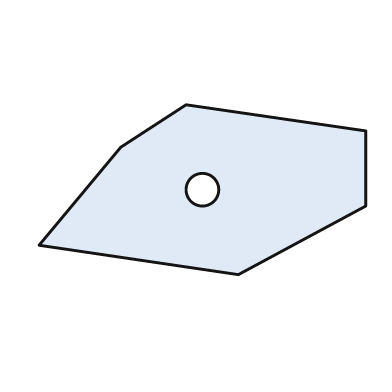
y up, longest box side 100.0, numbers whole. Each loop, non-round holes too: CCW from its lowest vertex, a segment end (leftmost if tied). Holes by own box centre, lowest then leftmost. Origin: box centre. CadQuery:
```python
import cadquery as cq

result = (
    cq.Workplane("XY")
    .moveTo(11.0, -26.0)
    .lineTo(50.0, -5.0)
    .lineTo(50.0, 18.0)
    .lineTo(-5.0, 26.0)
    .lineTo(-25.0, 13.0)
    .lineTo(-50.0, -17.0)
    .close()
    .moveTo(0.0, 0.0)
    .circle(5.0)
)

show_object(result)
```